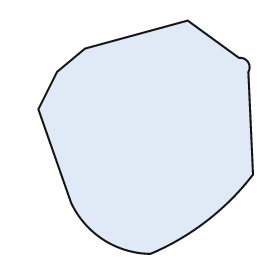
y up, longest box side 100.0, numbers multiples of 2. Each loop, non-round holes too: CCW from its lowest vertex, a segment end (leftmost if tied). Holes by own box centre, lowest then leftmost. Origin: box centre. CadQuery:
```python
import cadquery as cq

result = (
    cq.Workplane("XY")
    .moveTo(2.0, -50.0)
    .threePointArc((26.0, -36.0), (46.0, -16.0))
    .lineTo(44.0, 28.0)
    .threePointArc((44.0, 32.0), (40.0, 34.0))
    .lineTo(18.0, 50.0)
    .lineTo(-26.0, 38.0)
    .lineTo(-38.0, 28.0)
    .lineTo(-46.0, 12.0)
    .lineTo(-32.0, -28.0)
    .threePointArc((-18.0, -44.0), (2.0, -50.0))
    .close()
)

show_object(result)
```